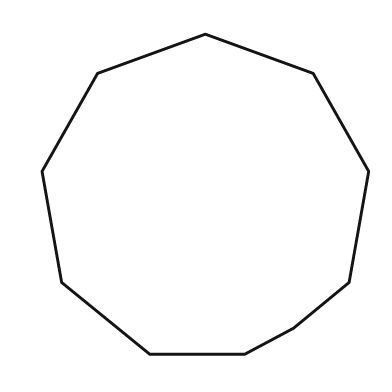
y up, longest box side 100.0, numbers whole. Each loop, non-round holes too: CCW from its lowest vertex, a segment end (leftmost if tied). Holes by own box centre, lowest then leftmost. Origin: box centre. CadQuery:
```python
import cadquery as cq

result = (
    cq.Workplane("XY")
    .moveTo(-17.0, -49.0)
    .lineTo(12.0, -49.0)
    .lineTo(27.0, -41.0)
    .lineTo(44.0, -27.0)
    .lineTo(50.0, 7.0)
    .lineTo(33.0, 37.0)
    .lineTo(0.0, 49.0)
    .lineTo(-33.0, 37.0)
    .lineTo(-50.0, 7.0)
    .lineTo(-44.0, -27.0)
    .close()
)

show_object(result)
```